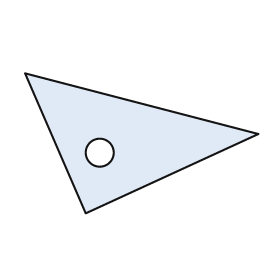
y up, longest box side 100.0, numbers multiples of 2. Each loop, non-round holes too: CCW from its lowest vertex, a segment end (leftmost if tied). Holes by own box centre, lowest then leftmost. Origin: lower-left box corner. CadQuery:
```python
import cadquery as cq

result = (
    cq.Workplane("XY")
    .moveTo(26.0, 0.0)
    .lineTo(100.0, 34.0)
    .lineTo(0.0, 60.0)
    .close()
    .moveTo(32.0, 26.0)
    .circle(6.0)
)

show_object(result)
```